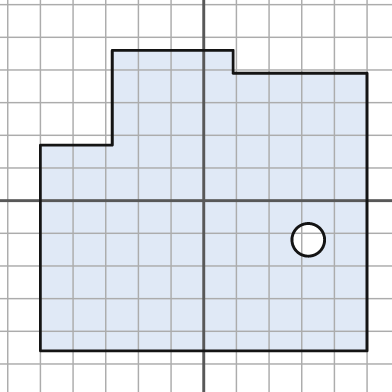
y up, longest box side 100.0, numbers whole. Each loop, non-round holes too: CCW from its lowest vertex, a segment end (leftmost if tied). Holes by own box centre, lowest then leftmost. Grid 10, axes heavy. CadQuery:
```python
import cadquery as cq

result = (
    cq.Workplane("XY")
    .moveTo(-50.0, -46.0)
    .lineTo(50.0, -46.0)
    .lineTo(50.0, 39.0)
    .lineTo(9.0, 39.0)
    .lineTo(9.0, 46.0)
    .lineTo(-28.0, 46.0)
    .lineTo(-28.0, 17.0)
    .lineTo(-50.0, 17.0)
    .close()
    .moveTo(32.0, -12.0)
    .circle(5.0)
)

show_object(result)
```